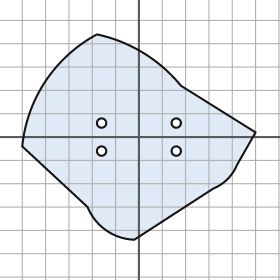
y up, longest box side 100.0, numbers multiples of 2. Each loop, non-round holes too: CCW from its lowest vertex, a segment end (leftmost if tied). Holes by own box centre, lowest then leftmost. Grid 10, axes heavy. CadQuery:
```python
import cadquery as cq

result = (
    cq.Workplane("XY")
    .moveTo(-2.0, -44.0)
    .lineTo(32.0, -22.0)
    .threePointArc((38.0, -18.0), (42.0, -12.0))
    .lineTo(50.0, 2.0)
    .lineTo(18.0, 22.0)
    .threePointArc((2.0, 36.0), (-18.0, 44.0))
    .threePointArc((-40.0, 24.0), (-50.0, -4.0))
    .lineTo(-22.0, -30.0)
    .threePointArc((-14.0, -40.0), (-2.0, -44.0))
    .close()
    .moveTo(-16.0, -6.0)
    .circle(2.0)
    .moveTo(16.0, -6.0)
    .circle(2.0)
    .moveTo(-16.0, 6.0)
    .circle(2.0)
    .moveTo(16.0, 6.0)
    .circle(2.0)
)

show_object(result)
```